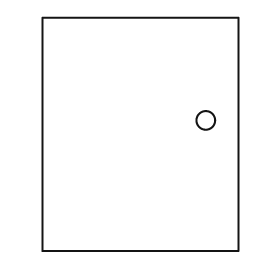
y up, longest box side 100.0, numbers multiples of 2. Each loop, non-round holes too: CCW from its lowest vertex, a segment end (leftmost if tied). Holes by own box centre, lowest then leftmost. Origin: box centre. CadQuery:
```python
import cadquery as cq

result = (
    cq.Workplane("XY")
    .moveTo(-42.0, -50.0)
    .lineTo(42.0, -50.0)
    .lineTo(42.0, 50.0)
    .lineTo(-42.0, 50.0)
    .close()
    .moveTo(28.0, 6.0)
    .circle(4.0)
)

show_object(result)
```